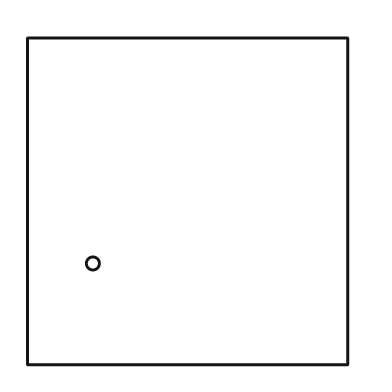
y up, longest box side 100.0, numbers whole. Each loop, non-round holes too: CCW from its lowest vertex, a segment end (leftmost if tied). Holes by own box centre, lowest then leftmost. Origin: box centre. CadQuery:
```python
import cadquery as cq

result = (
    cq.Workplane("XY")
    .moveTo(-49.0, -50.0)
    .lineTo(49.0, -50.0)
    .lineTo(49.0, 50.0)
    .lineTo(-49.0, 50.0)
    .close()
    .moveTo(-29.0, -19.0)
    .circle(2.0)
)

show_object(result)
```